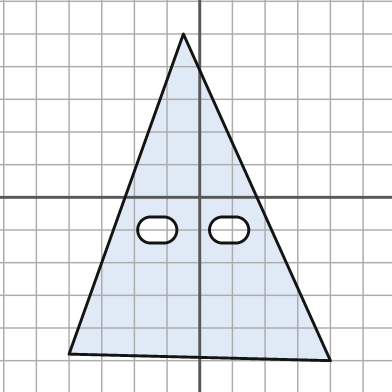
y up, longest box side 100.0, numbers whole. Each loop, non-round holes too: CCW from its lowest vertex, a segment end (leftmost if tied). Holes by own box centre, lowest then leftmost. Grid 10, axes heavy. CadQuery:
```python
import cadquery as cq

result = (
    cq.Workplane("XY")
    .moveTo(40.0, -50.0)
    .lineTo(-5.0, 50.0)
    .lineTo(-40.0, -48.0)
    .close()
    .moveTo(-15.0, -14.0)
    .lineTo(-11.0, -14.0)
    .threePointArc((-7.0, -10.0), (-11.0, -6.0))
    .lineTo(-15.0, -6.0)
    .threePointArc((-19.0, -10.0), (-15.0, -14.0))
    .close()
    .moveTo(7.0, -14.0)
    .lineTo(11.0, -14.0)
    .threePointArc((15.0, -10.0), (11.0, -6.0))
    .lineTo(7.0, -6.0)
    .threePointArc((3.0, -10.0), (7.0, -14.0))
    .close()
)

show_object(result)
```